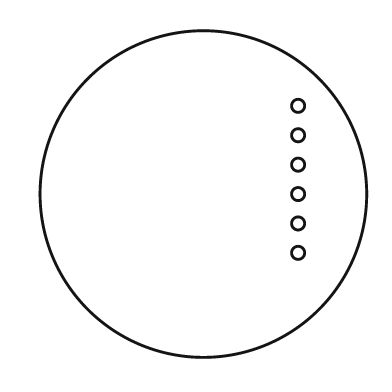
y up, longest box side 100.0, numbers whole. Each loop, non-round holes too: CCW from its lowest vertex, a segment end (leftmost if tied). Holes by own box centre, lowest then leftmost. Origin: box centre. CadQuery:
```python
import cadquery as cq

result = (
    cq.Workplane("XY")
    .moveTo(0.0, 0.0)
    .circle(50.0)
    .moveTo(29.0, -18.0)
    .circle(2.0)
    .moveTo(29.0, -9.0)
    .circle(2.0)
    .moveTo(29.0, 0.0)
    .circle(2.0)
    .moveTo(29.0, 9.0)
    .circle(2.0)
    .moveTo(29.0, 18.0)
    .circle(2.0)
    .moveTo(29.0, 27.0)
    .circle(2.0)
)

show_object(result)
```